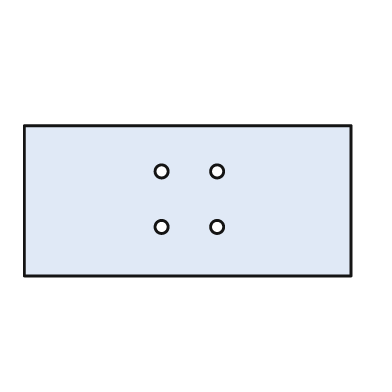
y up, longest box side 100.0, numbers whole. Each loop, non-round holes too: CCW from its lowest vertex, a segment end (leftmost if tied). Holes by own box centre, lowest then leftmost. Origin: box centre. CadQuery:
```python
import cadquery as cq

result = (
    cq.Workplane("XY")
    .moveTo(-50.0, -23.0)
    .lineTo(50.0, -23.0)
    .lineTo(50.0, 23.0)
    .lineTo(-50.0, 23.0)
    .close()
    .moveTo(-8.0, -8.0)
    .circle(2.0)
    .moveTo(9.0, -8.0)
    .circle(2.0)
    .moveTo(-8.0, 9.0)
    .circle(2.0)
    .moveTo(9.0, 9.0)
    .circle(2.0)
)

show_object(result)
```